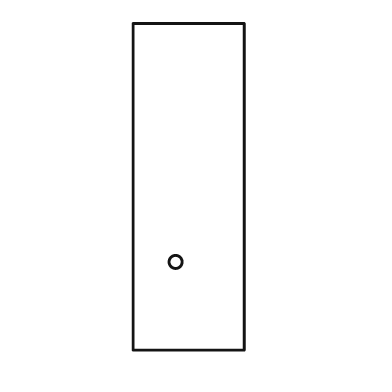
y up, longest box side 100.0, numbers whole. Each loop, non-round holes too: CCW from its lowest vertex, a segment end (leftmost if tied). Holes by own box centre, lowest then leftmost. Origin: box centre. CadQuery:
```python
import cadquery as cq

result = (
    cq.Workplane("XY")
    .moveTo(-17.0, -50.0)
    .lineTo(17.0, -50.0)
    .lineTo(17.0, 50.0)
    .lineTo(-17.0, 50.0)
    .close()
    .moveTo(-4.0, -23.0)
    .circle(2.0)
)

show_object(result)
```